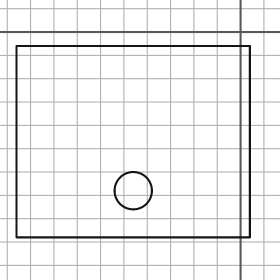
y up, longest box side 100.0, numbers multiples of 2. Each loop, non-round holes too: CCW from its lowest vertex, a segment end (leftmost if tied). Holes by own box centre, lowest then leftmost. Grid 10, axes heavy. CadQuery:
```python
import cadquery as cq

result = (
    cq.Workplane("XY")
    .moveTo(-96.0, -88.0)
    .lineTo(4.0, -88.0)
    .lineTo(4.0, -6.0)
    .lineTo(-96.0, -6.0)
    .close()
    .moveTo(-46.0, -68.0)
    .circle(8.0)
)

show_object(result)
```